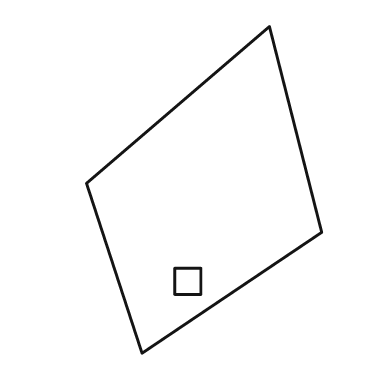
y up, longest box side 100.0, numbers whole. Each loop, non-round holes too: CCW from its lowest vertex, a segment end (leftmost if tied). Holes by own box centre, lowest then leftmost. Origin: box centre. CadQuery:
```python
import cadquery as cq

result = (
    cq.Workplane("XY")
    .moveTo(-19.0, -50.0)
    .lineTo(36.0, -13.0)
    .lineTo(20.0, 50.0)
    .lineTo(-36.0, 2.0)
    .close()
    .moveTo(-9.0, -32.0)
    .lineTo(-1.0, -32.0)
    .lineTo(-1.0, -24.0)
    .lineTo(-9.0, -24.0)
    .close()
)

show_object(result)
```